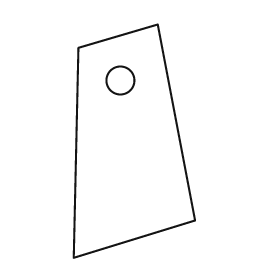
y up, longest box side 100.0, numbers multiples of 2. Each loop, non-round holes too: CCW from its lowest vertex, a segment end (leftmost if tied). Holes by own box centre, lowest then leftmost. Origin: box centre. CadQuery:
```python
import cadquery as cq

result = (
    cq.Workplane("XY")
    .moveTo(-26.0, -50.0)
    .lineTo(26.0, -34.0)
    .lineTo(10.0, 50.0)
    .lineTo(-24.0, 40.0)
    .close()
    .moveTo(-6.0, 26.0)
    .circle(6.0)
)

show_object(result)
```